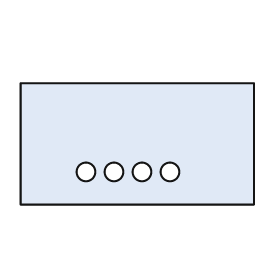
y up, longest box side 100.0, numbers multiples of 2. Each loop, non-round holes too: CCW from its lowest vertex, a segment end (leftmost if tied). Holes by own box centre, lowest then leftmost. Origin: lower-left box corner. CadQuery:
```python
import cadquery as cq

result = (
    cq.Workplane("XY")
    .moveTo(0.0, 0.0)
    .lineTo(100.0, 0.0)
    .lineTo(100.0, 52.0)
    .lineTo(0.0, 52.0)
    .close()
    .moveTo(28.0, 14.0)
    .circle(4.0)
    .moveTo(40.0, 14.0)
    .circle(4.0)
    .moveTo(52.0, 14.0)
    .circle(4.0)
    .moveTo(64.0, 14.0)
    .circle(4.0)
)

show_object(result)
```